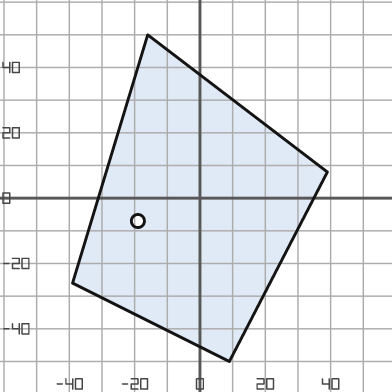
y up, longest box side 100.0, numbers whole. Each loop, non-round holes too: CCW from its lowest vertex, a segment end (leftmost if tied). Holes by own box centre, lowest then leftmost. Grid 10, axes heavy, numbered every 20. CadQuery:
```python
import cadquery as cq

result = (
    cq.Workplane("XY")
    .moveTo(9.0, -50.0)
    .lineTo(39.0, 8.0)
    .lineTo(-16.0, 50.0)
    .lineTo(-39.0, -26.0)
    .close()
    .moveTo(-19.0, -7.0)
    .circle(2.0)
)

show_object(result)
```